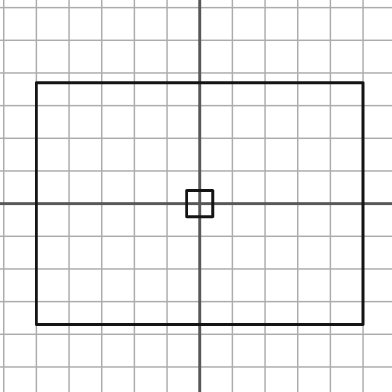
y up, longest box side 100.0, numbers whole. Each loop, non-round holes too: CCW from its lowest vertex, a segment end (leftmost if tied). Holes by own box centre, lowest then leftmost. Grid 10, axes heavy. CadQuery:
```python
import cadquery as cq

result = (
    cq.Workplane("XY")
    .moveTo(-50.0, -37.0)
    .lineTo(50.0, -37.0)
    .lineTo(50.0, 37.0)
    .lineTo(-50.0, 37.0)
    .close()
    .moveTo(-4.0, -4.0)
    .lineTo(4.0, -4.0)
    .lineTo(4.0, 4.0)
    .lineTo(-4.0, 4.0)
    .close()
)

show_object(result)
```